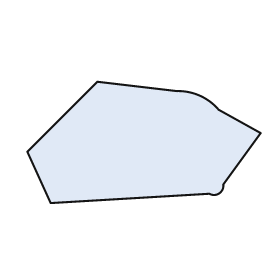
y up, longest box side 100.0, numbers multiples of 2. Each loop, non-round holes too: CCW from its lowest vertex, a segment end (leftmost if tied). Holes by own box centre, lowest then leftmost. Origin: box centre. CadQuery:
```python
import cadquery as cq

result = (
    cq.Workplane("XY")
    .moveTo(-40.0, -26.0)
    .lineTo(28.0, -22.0)
    .threePointArc((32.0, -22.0), (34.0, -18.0))
    .lineTo(50.0, 4.0)
    .lineTo(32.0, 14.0)
    .threePointArc((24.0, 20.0), (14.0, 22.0))
    .lineTo(-20.0, 26.0)
    .lineTo(-50.0, -4.0)
    .close()
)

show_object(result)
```